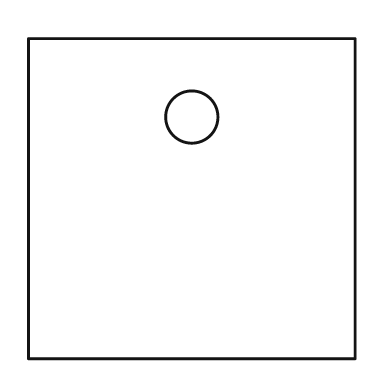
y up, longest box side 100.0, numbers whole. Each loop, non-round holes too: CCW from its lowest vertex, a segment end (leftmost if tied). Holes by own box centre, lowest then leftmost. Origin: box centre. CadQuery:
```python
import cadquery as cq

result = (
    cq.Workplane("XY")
    .moveTo(-50.0, -49.0)
    .lineTo(50.0, -49.0)
    .lineTo(50.0, 49.0)
    .lineTo(-50.0, 49.0)
    .close()
    .moveTo(0.0, 25.0)
    .circle(8.0)
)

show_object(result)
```